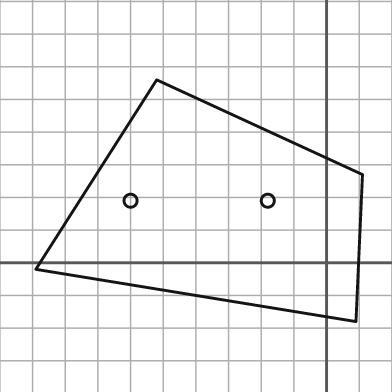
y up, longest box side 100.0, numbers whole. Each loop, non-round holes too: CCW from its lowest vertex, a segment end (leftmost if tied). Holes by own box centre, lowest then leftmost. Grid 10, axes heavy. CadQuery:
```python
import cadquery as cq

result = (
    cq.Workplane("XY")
    .moveTo(9.0, -18.0)
    .lineTo(11.0, 27.0)
    .lineTo(-52.0, 56.0)
    .lineTo(-89.0, -2.0)
    .close()
    .moveTo(-60.0, 19.0)
    .circle(2.0)
    .moveTo(-18.0, 19.0)
    .circle(2.0)
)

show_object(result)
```